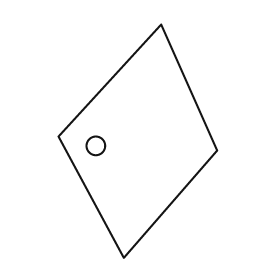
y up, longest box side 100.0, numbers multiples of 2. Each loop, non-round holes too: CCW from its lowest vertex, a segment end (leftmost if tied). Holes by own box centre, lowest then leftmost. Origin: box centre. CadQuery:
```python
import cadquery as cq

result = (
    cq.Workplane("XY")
    .moveTo(-6.0, -50.0)
    .lineTo(34.0, -4.0)
    .lineTo(10.0, 50.0)
    .lineTo(-34.0, 2.0)
    .close()
    .moveTo(-18.0, -2.0)
    .circle(4.0)
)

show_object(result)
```